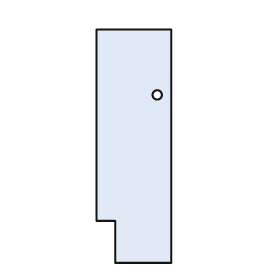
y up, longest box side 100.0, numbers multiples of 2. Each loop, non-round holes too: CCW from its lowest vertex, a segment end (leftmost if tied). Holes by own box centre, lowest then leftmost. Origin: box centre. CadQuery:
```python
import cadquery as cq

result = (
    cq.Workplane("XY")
    .moveTo(-8.0, -50.0)
    .lineTo(16.0, -50.0)
    .lineTo(16.0, 50.0)
    .lineTo(-16.0, 50.0)
    .lineTo(-16.0, -32.0)
    .lineTo(-8.0, -32.0)
    .close()
    .moveTo(10.0, 22.0)
    .circle(2.0)
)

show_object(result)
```